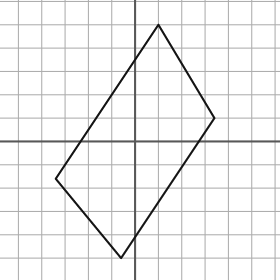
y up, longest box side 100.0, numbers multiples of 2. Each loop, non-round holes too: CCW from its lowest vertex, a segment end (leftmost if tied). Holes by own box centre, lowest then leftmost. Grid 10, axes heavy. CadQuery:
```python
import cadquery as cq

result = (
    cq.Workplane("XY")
    .moveTo(-6.0, -50.0)
    .lineTo(34.0, 10.0)
    .lineTo(10.0, 50.0)
    .lineTo(-34.0, -16.0)
    .close()
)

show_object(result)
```